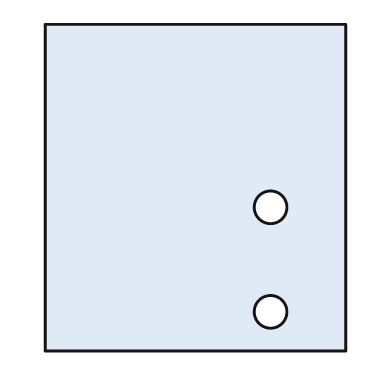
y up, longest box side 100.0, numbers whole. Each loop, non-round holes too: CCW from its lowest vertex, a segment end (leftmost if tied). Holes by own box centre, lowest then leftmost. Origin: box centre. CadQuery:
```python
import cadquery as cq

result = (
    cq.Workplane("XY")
    .moveTo(-46.0, -50.0)
    .lineTo(46.0, -50.0)
    .lineTo(46.0, 50.0)
    .lineTo(-46.0, 50.0)
    .close()
    .moveTo(23.0, -38.0)
    .circle(5.0)
    .moveTo(23.0, -6.0)
    .circle(5.0)
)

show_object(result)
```